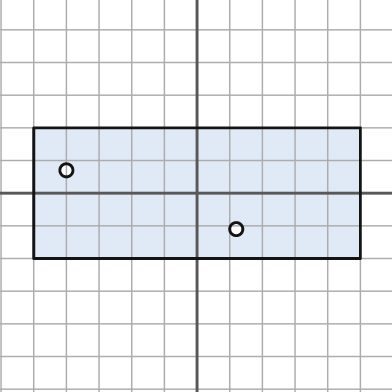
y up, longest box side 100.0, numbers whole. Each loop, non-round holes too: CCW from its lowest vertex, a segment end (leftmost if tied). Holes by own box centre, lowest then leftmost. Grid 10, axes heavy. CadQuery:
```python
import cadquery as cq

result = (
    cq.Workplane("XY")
    .moveTo(-50.0, -20.0)
    .lineTo(50.0, -20.0)
    .lineTo(50.0, 20.0)
    .lineTo(-50.0, 20.0)
    .close()
    .moveTo(12.0, -11.0)
    .circle(2.0)
    .moveTo(-40.0, 7.0)
    .circle(2.0)
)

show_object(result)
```